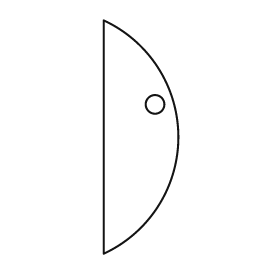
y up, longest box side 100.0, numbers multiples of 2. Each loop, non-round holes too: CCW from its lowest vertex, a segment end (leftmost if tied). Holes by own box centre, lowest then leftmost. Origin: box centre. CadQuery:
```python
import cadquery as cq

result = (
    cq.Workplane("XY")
    .moveTo(-16.0, -50.0)
    .threePointArc((16.0, 0.0), (-16.0, 50.0))
    .close()
    .moveTo(6.0, 14.0)
    .circle(4.0)
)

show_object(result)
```